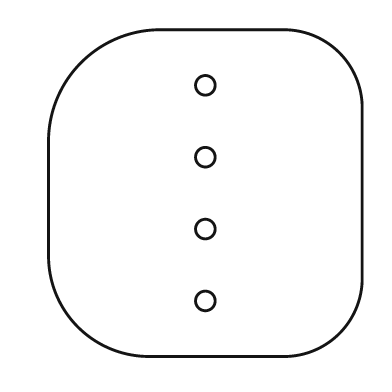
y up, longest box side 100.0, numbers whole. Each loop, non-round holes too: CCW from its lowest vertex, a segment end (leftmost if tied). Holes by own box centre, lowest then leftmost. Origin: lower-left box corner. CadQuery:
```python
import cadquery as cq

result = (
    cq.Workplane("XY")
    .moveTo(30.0, 0.0)
    .lineTo(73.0, 0.0)
    .threePointArc((89.0, 7.0), (96.0, 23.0))
    .lineTo(96.0, 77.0)
    .threePointArc((89.0, 93.0), (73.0, 100.0))
    .lineTo(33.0, 100.0)
    .threePointArc((10.0, 90.0), (0.0, 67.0))
    .lineTo(0.0, 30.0)
    .threePointArc((9.0, 9.0), (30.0, 0.0))
    .close()
    .moveTo(48.0, 17.0)
    .circle(3.0)
    .moveTo(48.0, 39.0)
    .circle(3.0)
    .moveTo(48.0, 61.0)
    .circle(3.0)
    .moveTo(48.0, 83.0)
    .circle(3.0)
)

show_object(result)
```